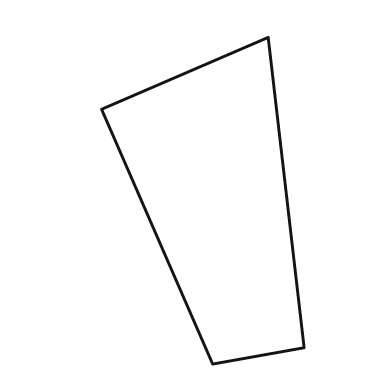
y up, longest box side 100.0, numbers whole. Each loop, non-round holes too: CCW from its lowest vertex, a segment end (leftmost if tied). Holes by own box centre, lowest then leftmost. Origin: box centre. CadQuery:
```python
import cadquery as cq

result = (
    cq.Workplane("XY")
    .moveTo(3.0, -50.0)
    .lineTo(31.0, -45.0)
    .lineTo(20.0, 50.0)
    .lineTo(-31.0, 28.0)
    .close()
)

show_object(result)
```